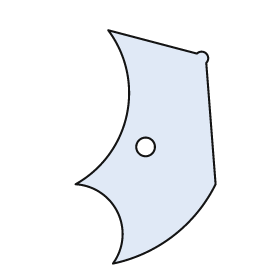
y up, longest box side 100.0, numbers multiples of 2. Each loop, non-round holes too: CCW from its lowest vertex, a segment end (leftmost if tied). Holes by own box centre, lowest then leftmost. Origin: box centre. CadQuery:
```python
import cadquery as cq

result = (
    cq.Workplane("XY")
    .moveTo(-14.0, -50.0)
    .threePointArc((12.0, -38.0), (30.0, -16.0))
    .lineTo(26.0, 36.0)
    .threePointArc((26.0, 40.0), (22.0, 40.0))
    .lineTo(-16.0, 50.0)
    .threePointArc((-8.0, 14.0), (-30.0, -16.0))
    .threePointArc((-12.0, -28.0), (-14.0, -50.0))
    .close()
    .moveTo(0.0, 0.0)
    .circle(4.0)
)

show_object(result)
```